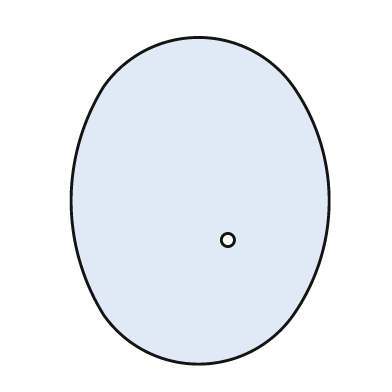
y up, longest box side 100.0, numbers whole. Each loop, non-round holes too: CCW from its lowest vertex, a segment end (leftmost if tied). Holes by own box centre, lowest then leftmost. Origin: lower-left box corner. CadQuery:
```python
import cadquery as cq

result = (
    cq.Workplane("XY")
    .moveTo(10.0, 15.0)
    .threePointArc((39.0, 0.0), (68.0, 15.0))
    .threePointArc((79.0, 50.0), (68.0, 85.0))
    .threePointArc((39.0, 100.0), (10.0, 85.0))
    .threePointArc((0.0, 50.0), (10.0, 15.0))
    .close()
    .moveTo(48.0, 38.0)
    .circle(2.0)
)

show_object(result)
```